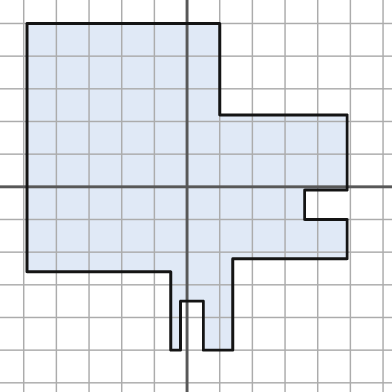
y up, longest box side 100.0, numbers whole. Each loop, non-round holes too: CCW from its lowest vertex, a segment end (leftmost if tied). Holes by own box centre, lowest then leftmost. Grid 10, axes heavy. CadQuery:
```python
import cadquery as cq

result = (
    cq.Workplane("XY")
    .moveTo(-5.0, -50.0)
    .lineTo(-2.0, -50.0)
    .lineTo(-2.0, -35.0)
    .lineTo(5.0, -35.0)
    .lineTo(5.0, -50.0)
    .lineTo(14.0, -50.0)
    .lineTo(14.0, -22.0)
    .lineTo(49.0, -22.0)
    .lineTo(49.0, -10.0)
    .lineTo(36.0, -10.0)
    .lineTo(36.0, -1.0)
    .lineTo(49.0, -1.0)
    .lineTo(49.0, 22.0)
    .lineTo(10.0, 22.0)
    .lineTo(10.0, 50.0)
    .lineTo(-49.0, 50.0)
    .lineTo(-49.0, -26.0)
    .lineTo(-5.0, -26.0)
    .close()
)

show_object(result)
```